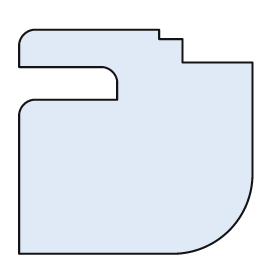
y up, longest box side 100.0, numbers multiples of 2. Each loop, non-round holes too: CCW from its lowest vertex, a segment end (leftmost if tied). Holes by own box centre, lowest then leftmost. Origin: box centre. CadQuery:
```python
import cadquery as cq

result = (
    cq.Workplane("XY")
    .moveTo(-50.0, -48.0)
    .lineTo(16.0, -48.0)
    .threePointArc((40.0, -38.0), (50.0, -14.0))
    .lineTo(50.0, 34.0)
    .lineTo(20.0, 34.0)
    .lineTo(20.0, 44.0)
    .lineTo(10.0, 44.0)
    .lineTo(10.0, 48.0)
    .lineTo(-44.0, 48.0)
    .threePointArc((-48.0, 46.0), (-50.0, 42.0))
    .lineTo(-50.0, 32.0)
    .lineTo(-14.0, 32.0)
    .threePointArc((-10.0, 30.0), (-8.0, 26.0))
    .lineTo(-8.0, 18.0)
    .lineTo(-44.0, 18.0)
    .threePointArc((-48.0, 16.0), (-50.0, 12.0))
    .close()
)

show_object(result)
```